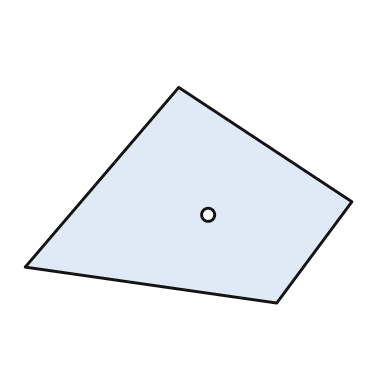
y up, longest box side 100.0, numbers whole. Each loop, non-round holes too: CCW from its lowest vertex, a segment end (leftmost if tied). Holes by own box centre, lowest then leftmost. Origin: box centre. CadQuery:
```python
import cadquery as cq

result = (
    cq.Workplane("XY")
    .moveTo(27.0, -33.0)
    .lineTo(50.0, -2.0)
    .lineTo(-3.0, 33.0)
    .lineTo(-50.0, -22.0)
    .close()
    .moveTo(6.0, -6.0)
    .circle(2.0)
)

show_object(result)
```